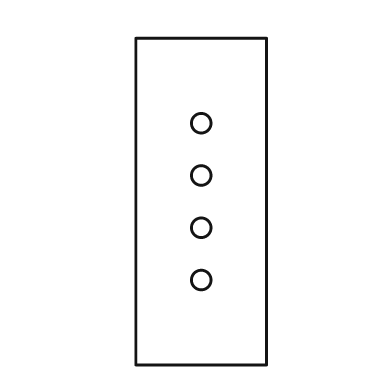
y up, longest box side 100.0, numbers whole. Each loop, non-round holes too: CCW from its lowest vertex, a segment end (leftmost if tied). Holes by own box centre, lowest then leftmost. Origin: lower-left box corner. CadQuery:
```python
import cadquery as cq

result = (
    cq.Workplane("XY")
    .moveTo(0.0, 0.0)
    .lineTo(40.0, 0.0)
    .lineTo(40.0, 100.0)
    .lineTo(0.0, 100.0)
    .close()
    .moveTo(20.0, 26.0)
    .circle(3.0)
    .moveTo(20.0, 42.0)
    .circle(3.0)
    .moveTo(20.0, 58.0)
    .circle(3.0)
    .moveTo(20.0, 74.0)
    .circle(3.0)
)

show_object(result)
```